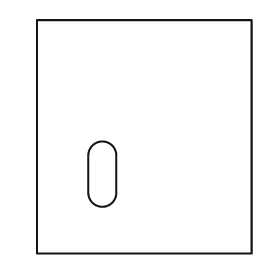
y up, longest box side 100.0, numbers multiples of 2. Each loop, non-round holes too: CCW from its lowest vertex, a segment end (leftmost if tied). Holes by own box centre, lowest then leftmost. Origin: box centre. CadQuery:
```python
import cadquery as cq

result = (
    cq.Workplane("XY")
    .moveTo(-46.0, -50.0)
    .lineTo(46.0, -50.0)
    .lineTo(46.0, 50.0)
    .lineTo(-46.0, 50.0)
    .close()
    .moveTo(-24.0, -24.0)
    .threePointArc((-18.0, -30.0), (-12.0, -24.0))
    .lineTo(-12.0, -8.0)
    .threePointArc((-18.0, -2.0), (-24.0, -8.0))
    .close()
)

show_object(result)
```